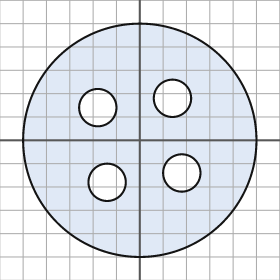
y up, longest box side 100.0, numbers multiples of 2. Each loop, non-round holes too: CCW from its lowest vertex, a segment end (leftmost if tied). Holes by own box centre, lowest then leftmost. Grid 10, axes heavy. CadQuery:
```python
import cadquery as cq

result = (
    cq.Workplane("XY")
    .moveTo(0.0, 0.0)
    .circle(50.0)
    .moveTo(-14.0, -18.0)
    .circle(8.0)
    .moveTo(18.0, -14.0)
    .circle(8.0)
    .moveTo(-18.0, 14.0)
    .circle(8.0)
    .moveTo(14.0, 18.0)
    .circle(8.0)
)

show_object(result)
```